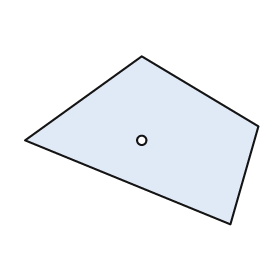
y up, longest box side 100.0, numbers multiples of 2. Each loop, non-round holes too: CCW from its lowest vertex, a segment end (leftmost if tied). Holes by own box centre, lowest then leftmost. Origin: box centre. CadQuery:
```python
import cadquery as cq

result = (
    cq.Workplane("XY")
    .moveTo(38.0, -36.0)
    .lineTo(50.0, 6.0)
    .lineTo(0.0, 36.0)
    .lineTo(-50.0, 0.0)
    .close()
    .moveTo(0.0, 0.0)
    .circle(2.0)
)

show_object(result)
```